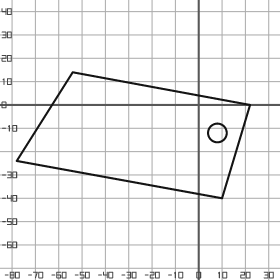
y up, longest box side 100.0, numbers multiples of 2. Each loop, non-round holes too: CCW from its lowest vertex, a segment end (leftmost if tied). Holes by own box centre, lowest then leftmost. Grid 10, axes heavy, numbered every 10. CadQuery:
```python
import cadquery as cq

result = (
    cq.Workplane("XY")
    .moveTo(10.0, -40.0)
    .lineTo(22.0, 0.0)
    .lineTo(-54.0, 14.0)
    .lineTo(-78.0, -24.0)
    .close()
    .moveTo(8.0, -12.0)
    .circle(4.0)
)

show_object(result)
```